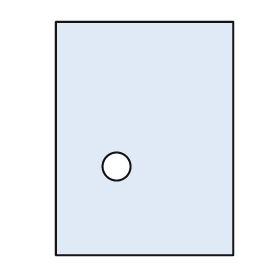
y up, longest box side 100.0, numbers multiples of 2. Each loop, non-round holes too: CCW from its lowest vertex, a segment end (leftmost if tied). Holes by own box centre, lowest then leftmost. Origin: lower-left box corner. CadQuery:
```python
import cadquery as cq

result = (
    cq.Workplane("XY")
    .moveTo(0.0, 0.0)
    .lineTo(76.0, 0.0)
    .lineTo(76.0, 100.0)
    .lineTo(0.0, 100.0)
    .close()
    .moveTo(26.0, 38.0)
    .circle(6.0)
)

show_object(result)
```